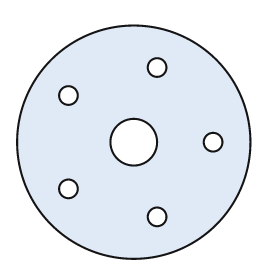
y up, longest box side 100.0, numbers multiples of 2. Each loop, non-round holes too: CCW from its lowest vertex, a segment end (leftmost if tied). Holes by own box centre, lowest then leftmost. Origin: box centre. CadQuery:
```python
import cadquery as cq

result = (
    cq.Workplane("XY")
    .moveTo(0.0, 0.0)
    .circle(50.0)
    .moveTo(10.0, -32.0)
    .circle(4.0)
    .moveTo(-28.0, -20.0)
    .circle(4.0)
    .moveTo(0.0, 0.0)
    .circle(10.0)
    .moveTo(34.0, 0.0)
    .circle(4.0)
    .moveTo(-28.0, 20.0)
    .circle(4.0)
    .moveTo(10.0, 32.0)
    .circle(4.0)
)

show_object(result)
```